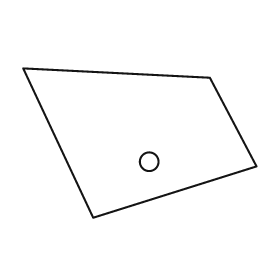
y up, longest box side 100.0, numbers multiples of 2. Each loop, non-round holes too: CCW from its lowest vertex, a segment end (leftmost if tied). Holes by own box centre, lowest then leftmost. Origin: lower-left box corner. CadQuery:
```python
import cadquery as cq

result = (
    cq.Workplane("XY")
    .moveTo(30.0, 0.0)
    .lineTo(100.0, 22.0)
    .lineTo(80.0, 60.0)
    .lineTo(0.0, 64.0)
    .close()
    .moveTo(54.0, 24.0)
    .circle(4.0)
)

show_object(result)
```